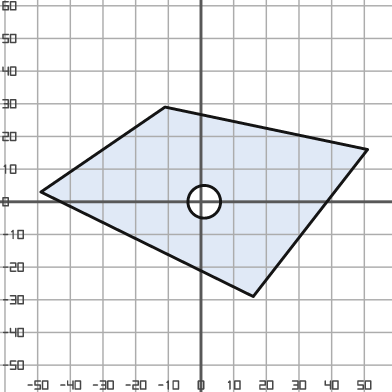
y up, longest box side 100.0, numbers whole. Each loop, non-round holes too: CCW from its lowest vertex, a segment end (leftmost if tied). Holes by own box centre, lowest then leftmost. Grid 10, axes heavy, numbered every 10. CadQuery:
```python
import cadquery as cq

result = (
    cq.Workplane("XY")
    .moveTo(16.0, -29.0)
    .lineTo(51.0, 16.0)
    .lineTo(-11.0, 29.0)
    .lineTo(-49.0, 3.0)
    .close()
    .moveTo(1.0, 0.0)
    .circle(5.0)
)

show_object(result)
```